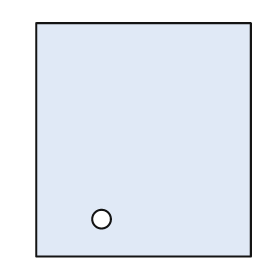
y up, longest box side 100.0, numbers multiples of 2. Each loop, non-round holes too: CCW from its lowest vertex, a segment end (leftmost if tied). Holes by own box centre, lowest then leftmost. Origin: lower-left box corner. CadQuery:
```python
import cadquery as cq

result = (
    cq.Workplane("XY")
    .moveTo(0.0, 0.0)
    .lineTo(92.0, 0.0)
    .lineTo(92.0, 100.0)
    .lineTo(0.0, 100.0)
    .close()
    .moveTo(28.0, 16.0)
    .circle(4.0)
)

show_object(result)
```